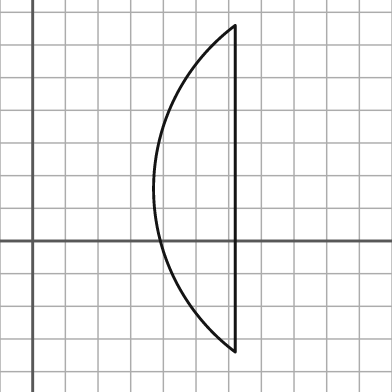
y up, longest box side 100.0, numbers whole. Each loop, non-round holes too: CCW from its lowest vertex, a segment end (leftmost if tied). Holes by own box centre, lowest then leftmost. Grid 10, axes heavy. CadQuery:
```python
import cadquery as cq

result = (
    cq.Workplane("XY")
    .moveTo(62.0, -34.0)
    .lineTo(62.0, 66.0)
    .threePointArc((37.0, 16.0), (62.0, -34.0))
    .close()
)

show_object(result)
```